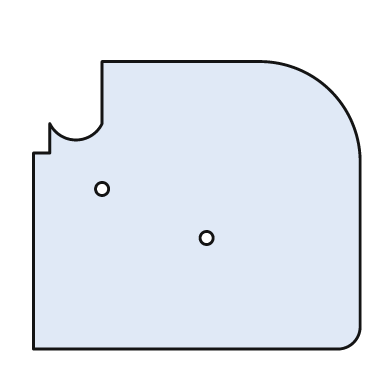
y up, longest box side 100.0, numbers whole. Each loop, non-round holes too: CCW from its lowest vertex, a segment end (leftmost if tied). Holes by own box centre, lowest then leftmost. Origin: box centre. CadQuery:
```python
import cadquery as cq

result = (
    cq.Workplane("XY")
    .moveTo(-50.0, -44.0)
    .lineTo(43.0, -44.0)
    .threePointArc((48.0, -42.0), (50.0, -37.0))
    .lineTo(50.0, 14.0)
    .threePointArc((41.0, 35.0), (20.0, 44.0))
    .lineTo(-29.0, 44.0)
    .lineTo(-29.0, 25.0)
    .threePointArc((-37.0, 20.0), (-45.0, 25.0))
    .lineTo(-45.0, 16.0)
    .lineTo(-50.0, 16.0)
    .close()
    .moveTo(3.0, -10.0)
    .circle(2.0)
    .moveTo(-29.0, 5.0)
    .circle(2.0)
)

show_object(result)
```